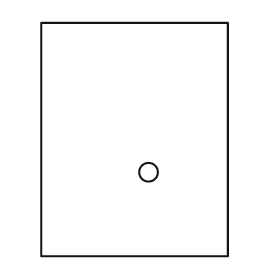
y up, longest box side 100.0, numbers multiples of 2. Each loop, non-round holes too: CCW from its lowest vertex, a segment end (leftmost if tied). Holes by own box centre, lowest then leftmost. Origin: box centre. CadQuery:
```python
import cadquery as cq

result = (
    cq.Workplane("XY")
    .moveTo(-40.0, -50.0)
    .lineTo(40.0, -50.0)
    .lineTo(40.0, 50.0)
    .lineTo(-40.0, 50.0)
    .close()
    .moveTo(6.0, -14.0)
    .circle(4.0)
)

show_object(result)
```